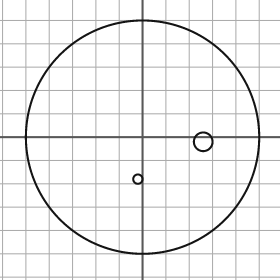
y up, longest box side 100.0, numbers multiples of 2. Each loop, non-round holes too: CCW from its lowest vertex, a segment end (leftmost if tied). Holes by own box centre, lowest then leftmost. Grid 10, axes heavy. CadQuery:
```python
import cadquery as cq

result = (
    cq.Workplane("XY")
    .moveTo(0.0, 0.0)
    .circle(50.0)
    .moveTo(-2.0, -18.0)
    .circle(2.0)
    .moveTo(26.0, -2.0)
    .circle(4.0)
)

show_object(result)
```